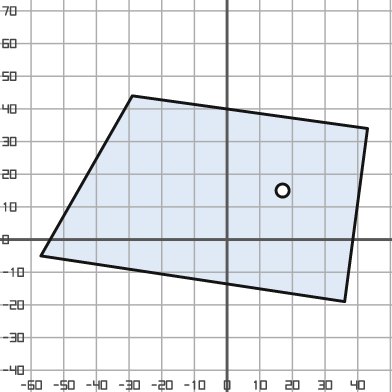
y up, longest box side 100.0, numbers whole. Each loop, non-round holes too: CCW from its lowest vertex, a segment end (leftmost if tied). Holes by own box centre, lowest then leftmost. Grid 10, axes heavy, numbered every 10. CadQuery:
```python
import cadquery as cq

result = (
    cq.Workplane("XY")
    .moveTo(36.0, -19.0)
    .lineTo(43.0, 34.0)
    .lineTo(-29.0, 44.0)
    .lineTo(-57.0, -5.0)
    .close()
    .moveTo(17.0, 15.0)
    .circle(2.0)
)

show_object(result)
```